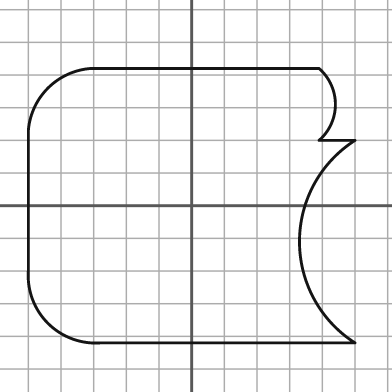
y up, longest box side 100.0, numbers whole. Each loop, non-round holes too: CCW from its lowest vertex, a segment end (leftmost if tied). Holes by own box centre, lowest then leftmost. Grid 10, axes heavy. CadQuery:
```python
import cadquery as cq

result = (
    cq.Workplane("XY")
    .moveTo(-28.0, -42.0)
    .lineTo(50.0, -42.0)
    .threePointArc((33.0, -11.0), (50.0, 20.0))
    .lineTo(39.0, 20.0)
    .threePointArc((44.0, 31.0), (39.0, 42.0))
    .lineTo(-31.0, 42.0)
    .threePointArc((-44.0, 36.0), (-50.0, 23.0))
    .lineTo(-50.0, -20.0)
    .threePointArc((-44.0, -36.0), (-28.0, -42.0))
    .close()
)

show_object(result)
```